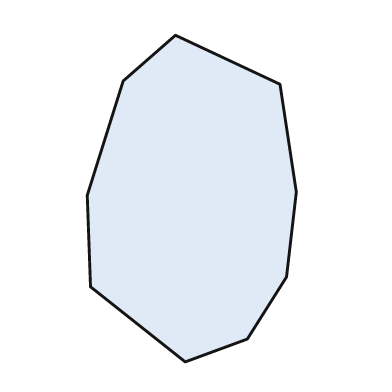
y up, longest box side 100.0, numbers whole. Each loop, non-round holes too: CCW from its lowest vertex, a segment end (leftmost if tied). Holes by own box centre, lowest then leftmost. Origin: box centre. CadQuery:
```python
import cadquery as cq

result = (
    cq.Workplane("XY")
    .moveTo(-2.0, -50.0)
    .lineTo(17.0, -43.0)
    .lineTo(29.0, -24.0)
    .lineTo(32.0, 2.0)
    .lineTo(27.0, 35.0)
    .lineTo(-5.0, 50.0)
    .lineTo(-21.0, 36.0)
    .lineTo(-32.0, 1.0)
    .lineTo(-31.0, -27.0)
    .close()
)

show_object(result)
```